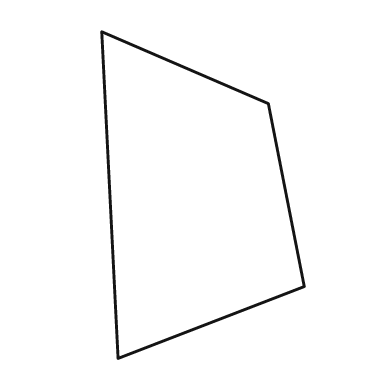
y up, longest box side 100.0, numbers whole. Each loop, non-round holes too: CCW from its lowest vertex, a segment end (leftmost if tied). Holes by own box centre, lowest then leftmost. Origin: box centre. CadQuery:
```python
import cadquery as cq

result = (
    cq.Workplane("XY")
    .moveTo(-26.0, -50.0)
    .lineTo(31.0, -28.0)
    .lineTo(20.0, 28.0)
    .lineTo(-31.0, 50.0)
    .close()
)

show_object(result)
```